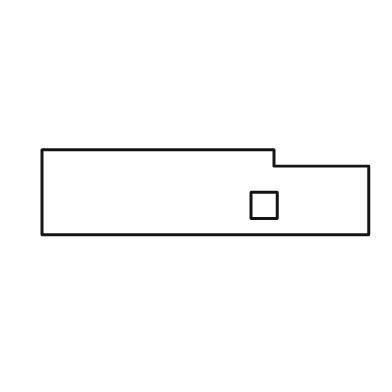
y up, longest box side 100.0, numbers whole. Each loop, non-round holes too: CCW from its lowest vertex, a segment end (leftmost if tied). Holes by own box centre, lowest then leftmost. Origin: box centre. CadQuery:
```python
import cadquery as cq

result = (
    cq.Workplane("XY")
    .moveTo(-50.0, -13.0)
    .lineTo(50.0, -13.0)
    .lineTo(50.0, 8.0)
    .lineTo(21.0, 8.0)
    .lineTo(21.0, 13.0)
    .lineTo(-50.0, 13.0)
    .close()
    .moveTo(14.0, -8.0)
    .lineTo(22.0, -8.0)
    .lineTo(22.0, 0.0)
    .lineTo(14.0, 0.0)
    .close()
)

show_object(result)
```